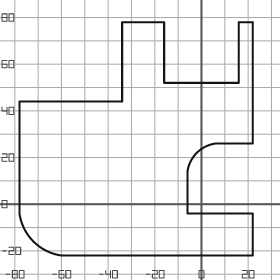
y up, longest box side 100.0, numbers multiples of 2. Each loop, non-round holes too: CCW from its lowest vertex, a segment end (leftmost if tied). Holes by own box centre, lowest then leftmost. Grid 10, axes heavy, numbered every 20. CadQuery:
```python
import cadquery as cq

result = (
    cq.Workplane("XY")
    .moveTo(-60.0, -22.0)
    .lineTo(22.0, -22.0)
    .lineTo(22.0, -4.0)
    .lineTo(-6.0, -4.0)
    .lineTo(-6.0, 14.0)
    .threePointArc((-2.0, 22.0), (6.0, 26.0))
    .lineTo(22.0, 26.0)
    .lineTo(22.0, 78.0)
    .lineTo(16.0, 78.0)
    .lineTo(16.0, 52.0)
    .lineTo(-16.0, 52.0)
    .lineTo(-16.0, 78.0)
    .lineTo(-34.0, 78.0)
    .lineTo(-34.0, 44.0)
    .lineTo(-78.0, 44.0)
    .lineTo(-78.0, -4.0)
    .threePointArc((-72.0, -16.0), (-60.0, -22.0))
    .close()
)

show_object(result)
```